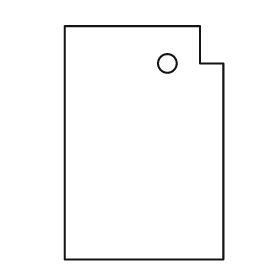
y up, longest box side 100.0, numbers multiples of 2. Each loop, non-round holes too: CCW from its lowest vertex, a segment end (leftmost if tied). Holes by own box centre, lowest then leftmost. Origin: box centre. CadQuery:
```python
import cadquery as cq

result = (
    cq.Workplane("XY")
    .moveTo(-34.0, -50.0)
    .lineTo(34.0, -50.0)
    .lineTo(34.0, 34.0)
    .lineTo(24.0, 34.0)
    .lineTo(24.0, 50.0)
    .lineTo(-34.0, 50.0)
    .close()
    .moveTo(10.0, 34.0)
    .circle(4.0)
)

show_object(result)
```